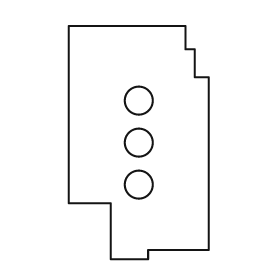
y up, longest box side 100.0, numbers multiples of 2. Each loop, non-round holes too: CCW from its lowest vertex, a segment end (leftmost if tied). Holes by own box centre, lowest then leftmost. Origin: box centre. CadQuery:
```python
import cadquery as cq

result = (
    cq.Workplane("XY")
    .moveTo(-12.0, -50.0)
    .lineTo(4.0, -50.0)
    .lineTo(4.0, -46.0)
    .lineTo(30.0, -46.0)
    .lineTo(30.0, 28.0)
    .lineTo(24.0, 28.0)
    .lineTo(24.0, 40.0)
    .lineTo(20.0, 40.0)
    .lineTo(20.0, 50.0)
    .lineTo(-30.0, 50.0)
    .lineTo(-30.0, -26.0)
    .lineTo(-12.0, -26.0)
    .close()
    .moveTo(0.0, -18.0)
    .circle(6.0)
    .moveTo(0.0, 0.0)
    .circle(6.0)
    .moveTo(0.0, 18.0)
    .circle(6.0)
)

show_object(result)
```